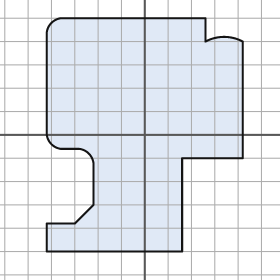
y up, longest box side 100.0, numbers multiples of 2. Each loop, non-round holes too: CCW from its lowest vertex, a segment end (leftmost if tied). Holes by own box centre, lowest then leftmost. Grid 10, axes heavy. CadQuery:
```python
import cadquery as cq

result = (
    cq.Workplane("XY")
    .moveTo(-42.0, -50.0)
    .lineTo(16.0, -50.0)
    .lineTo(16.0, -10.0)
    .lineTo(42.0, -10.0)
    .lineTo(42.0, 40.0)
    .threePointArc((34.0, 42.0), (26.0, 40.0))
    .lineTo(26.0, 50.0)
    .lineTo(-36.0, 50.0)
    .threePointArc((-40.0, 48.0), (-42.0, 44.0))
    .lineTo(-42.0, 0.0)
    .threePointArc((-40.0, -4.0), (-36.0, -6.0))
    .lineTo(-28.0, -6.0)
    .threePointArc((-24.0, -8.0), (-22.0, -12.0))
    .lineTo(-22.0, -30.0)
    .lineTo(-30.0, -38.0)
    .lineTo(-42.0, -38.0)
    .close()
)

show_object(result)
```